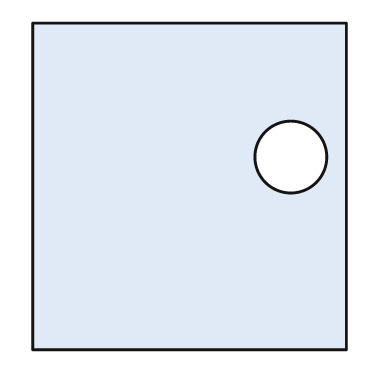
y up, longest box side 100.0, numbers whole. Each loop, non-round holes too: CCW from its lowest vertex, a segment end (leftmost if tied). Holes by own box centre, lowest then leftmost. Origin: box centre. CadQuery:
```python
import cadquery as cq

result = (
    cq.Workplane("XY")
    .moveTo(-48.0, -50.0)
    .lineTo(48.0, -50.0)
    .lineTo(48.0, 50.0)
    .lineTo(-48.0, 50.0)
    .close()
    .moveTo(31.0, 9.0)
    .circle(11.0)
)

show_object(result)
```